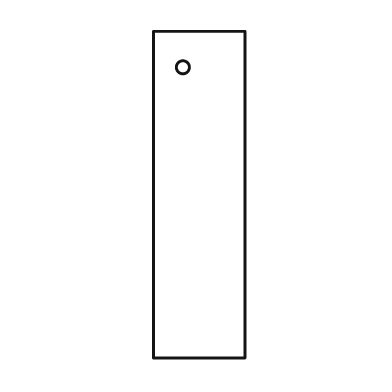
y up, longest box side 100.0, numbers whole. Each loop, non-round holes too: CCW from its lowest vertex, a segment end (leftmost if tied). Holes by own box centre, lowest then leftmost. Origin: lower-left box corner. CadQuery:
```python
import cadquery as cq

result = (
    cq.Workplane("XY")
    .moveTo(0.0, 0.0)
    .lineTo(28.0, 0.0)
    .lineTo(28.0, 100.0)
    .lineTo(0.0, 100.0)
    .close()
    .moveTo(9.0, 89.0)
    .circle(2.0)
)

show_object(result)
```